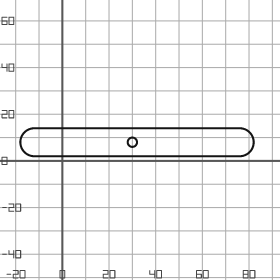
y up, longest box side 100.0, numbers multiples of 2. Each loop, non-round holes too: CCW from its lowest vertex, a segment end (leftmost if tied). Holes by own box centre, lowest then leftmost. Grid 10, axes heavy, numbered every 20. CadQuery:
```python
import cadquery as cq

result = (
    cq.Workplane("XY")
    .moveTo(-12.0, 2.0)
    .lineTo(76.0, 2.0)
    .threePointArc((82.0, 8.0), (76.0, 14.0))
    .lineTo(-12.0, 14.0)
    .threePointArc((-18.0, 8.0), (-12.0, 2.0))
    .close()
    .moveTo(30.0, 8.0)
    .circle(2.0)
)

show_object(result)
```